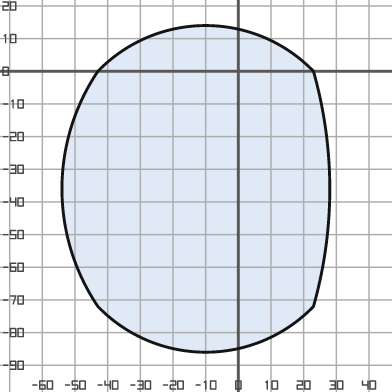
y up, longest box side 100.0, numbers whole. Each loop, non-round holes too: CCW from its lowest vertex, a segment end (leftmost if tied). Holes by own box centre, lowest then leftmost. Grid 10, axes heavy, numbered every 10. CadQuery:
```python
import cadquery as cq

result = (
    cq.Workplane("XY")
    .moveTo(-43.0, -72.0)
    .threePointArc((-10.0, -86.0), (23.0, -72.0))
    .threePointArc((28.0, -36.0), (23.0, 0.0))
    .threePointArc((-10.0, 14.0), (-43.0, 0.0))
    .threePointArc((-54.0, -36.0), (-43.0, -72.0))
    .close()
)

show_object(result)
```